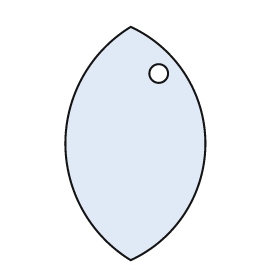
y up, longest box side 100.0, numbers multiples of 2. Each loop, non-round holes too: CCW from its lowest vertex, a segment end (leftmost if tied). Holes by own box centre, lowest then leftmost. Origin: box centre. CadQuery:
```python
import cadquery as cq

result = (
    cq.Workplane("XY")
    .moveTo(-2.0, -50.0)
    .threePointArc((30.0, 0.0), (-2.0, 50.0))
    .threePointArc((-30.0, 0.0), (-2.0, -50.0))
    .close()
    .moveTo(10.0, 30.0)
    .circle(4.0)
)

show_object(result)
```